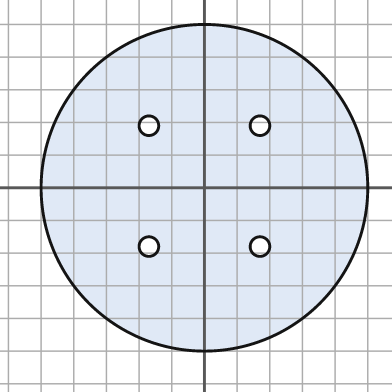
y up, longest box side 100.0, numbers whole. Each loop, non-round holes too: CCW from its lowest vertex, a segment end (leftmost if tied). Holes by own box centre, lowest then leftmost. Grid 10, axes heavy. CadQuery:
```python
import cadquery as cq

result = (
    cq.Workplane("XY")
    .moveTo(0.0, 0.0)
    .circle(50.0)
    .moveTo(-17.0, -18.0)
    .circle(3.0)
    .moveTo(17.0, -18.0)
    .circle(3.0)
    .moveTo(-17.0, 19.0)
    .circle(3.0)
    .moveTo(17.0, 19.0)
    .circle(3.0)
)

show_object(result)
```